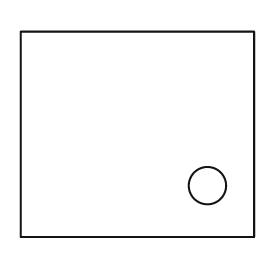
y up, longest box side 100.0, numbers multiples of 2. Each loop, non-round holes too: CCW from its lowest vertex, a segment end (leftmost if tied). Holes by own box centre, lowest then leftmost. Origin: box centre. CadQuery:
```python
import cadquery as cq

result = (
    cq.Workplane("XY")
    .moveTo(-50.0, -44.0)
    .lineTo(50.0, -44.0)
    .lineTo(50.0, 44.0)
    .lineTo(-50.0, 44.0)
    .close()
    .moveTo(30.0, -22.0)
    .circle(8.0)
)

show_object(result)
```